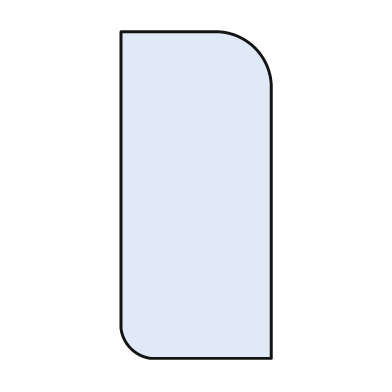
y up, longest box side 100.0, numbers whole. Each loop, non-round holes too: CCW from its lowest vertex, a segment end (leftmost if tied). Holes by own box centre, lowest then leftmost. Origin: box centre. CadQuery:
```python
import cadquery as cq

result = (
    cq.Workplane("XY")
    .moveTo(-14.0, -50.0)
    .lineTo(23.0, -50.0)
    .lineTo(23.0, 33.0)
    .threePointArc((18.0, 45.0), (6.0, 50.0))
    .lineTo(-23.0, 50.0)
    .lineTo(-23.0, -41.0)
    .threePointArc((-20.0, -47.0), (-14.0, -50.0))
    .close()
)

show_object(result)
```